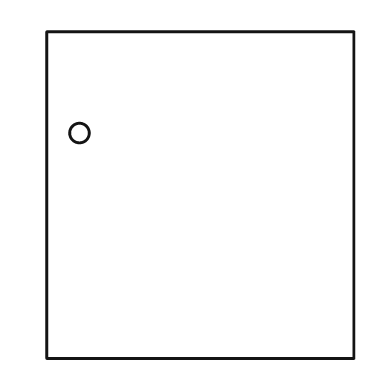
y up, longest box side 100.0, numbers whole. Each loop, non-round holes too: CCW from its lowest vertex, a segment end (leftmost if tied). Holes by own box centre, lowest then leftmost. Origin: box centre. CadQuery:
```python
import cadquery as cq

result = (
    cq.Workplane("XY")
    .moveTo(-47.0, -50.0)
    .lineTo(47.0, -50.0)
    .lineTo(47.0, 50.0)
    .lineTo(-47.0, 50.0)
    .close()
    .moveTo(-37.0, 19.0)
    .circle(3.0)
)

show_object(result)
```